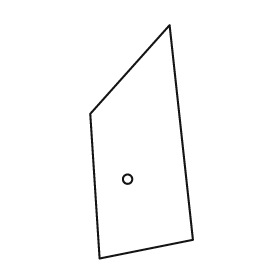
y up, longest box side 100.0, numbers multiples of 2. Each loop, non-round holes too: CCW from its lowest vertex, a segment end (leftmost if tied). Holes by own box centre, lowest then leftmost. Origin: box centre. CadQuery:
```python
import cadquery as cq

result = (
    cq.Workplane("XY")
    .moveTo(-18.0, -50.0)
    .lineTo(22.0, -42.0)
    .lineTo(12.0, 50.0)
    .lineTo(-22.0, 12.0)
    .close()
    .moveTo(-6.0, -16.0)
    .circle(2.0)
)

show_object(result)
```